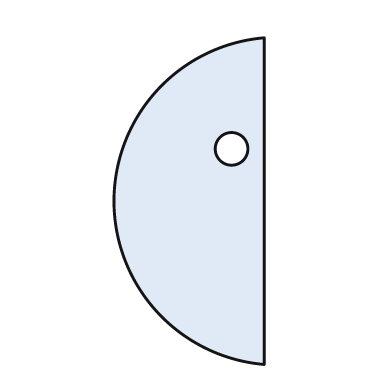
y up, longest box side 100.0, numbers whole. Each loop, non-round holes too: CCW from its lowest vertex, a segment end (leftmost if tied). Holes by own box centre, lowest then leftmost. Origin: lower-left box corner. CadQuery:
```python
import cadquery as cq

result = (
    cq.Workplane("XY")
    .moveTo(46.0, 0.0)
    .lineTo(46.0, 100.0)
    .threePointArc((0.0, 50.0), (46.0, 0.0))
    .close()
    .moveTo(36.0, 66.0)
    .circle(5.0)
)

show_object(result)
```